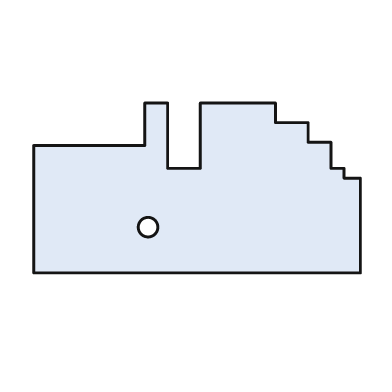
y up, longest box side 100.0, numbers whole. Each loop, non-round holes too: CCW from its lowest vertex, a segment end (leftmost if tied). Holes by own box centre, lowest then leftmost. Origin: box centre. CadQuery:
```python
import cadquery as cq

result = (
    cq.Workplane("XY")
    .moveTo(-50.0, -26.0)
    .lineTo(50.0, -26.0)
    .lineTo(50.0, 3.0)
    .lineTo(45.0, 3.0)
    .lineTo(45.0, 6.0)
    .lineTo(41.0, 6.0)
    .lineTo(41.0, 14.0)
    .lineTo(34.0, 14.0)
    .lineTo(34.0, 20.0)
    .lineTo(24.0, 20.0)
    .lineTo(24.0, 26.0)
    .lineTo(1.0, 26.0)
    .lineTo(1.0, 6.0)
    .lineTo(-9.0, 6.0)
    .lineTo(-9.0, 26.0)
    .lineTo(-16.0, 26.0)
    .lineTo(-16.0, 13.0)
    .lineTo(-50.0, 13.0)
    .close()
    .moveTo(-15.0, -12.0)
    .circle(3.0)
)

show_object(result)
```